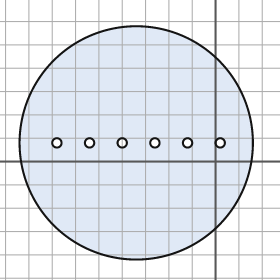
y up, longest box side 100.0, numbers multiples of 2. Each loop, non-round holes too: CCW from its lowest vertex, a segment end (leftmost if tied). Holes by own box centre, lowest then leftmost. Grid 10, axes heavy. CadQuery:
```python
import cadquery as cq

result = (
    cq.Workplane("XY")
    .moveTo(-34.0, 8.0)
    .circle(50.0)
    .moveTo(-68.0, 8.0)
    .circle(2.0)
    .moveTo(-54.0, 8.0)
    .circle(2.0)
    .moveTo(-40.0, 8.0)
    .circle(2.0)
    .moveTo(-26.0, 8.0)
    .circle(2.0)
    .moveTo(-12.0, 8.0)
    .circle(2.0)
    .moveTo(2.0, 8.0)
    .circle(2.0)
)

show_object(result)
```